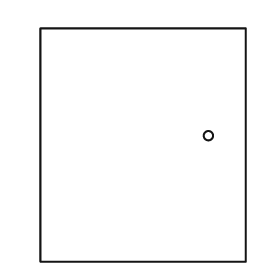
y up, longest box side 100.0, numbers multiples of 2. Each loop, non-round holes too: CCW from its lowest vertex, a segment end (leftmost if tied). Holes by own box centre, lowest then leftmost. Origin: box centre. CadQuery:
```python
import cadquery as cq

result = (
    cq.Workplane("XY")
    .moveTo(-44.0, -50.0)
    .lineTo(44.0, -50.0)
    .lineTo(44.0, 50.0)
    .lineTo(-44.0, 50.0)
    .close()
    .moveTo(28.0, 4.0)
    .circle(2.0)
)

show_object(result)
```